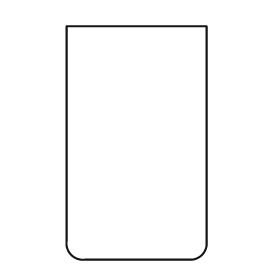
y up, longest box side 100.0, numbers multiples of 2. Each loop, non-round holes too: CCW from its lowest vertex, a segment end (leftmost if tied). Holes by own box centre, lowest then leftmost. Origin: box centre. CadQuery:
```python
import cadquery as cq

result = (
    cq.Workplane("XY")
    .moveTo(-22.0, -50.0)
    .lineTo(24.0, -50.0)
    .threePointArc((28.0, -48.0), (30.0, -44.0))
    .lineTo(30.0, 50.0)
    .lineTo(-30.0, 50.0)
    .lineTo(-30.0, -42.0)
    .threePointArc((-28.0, -48.0), (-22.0, -50.0))
    .close()
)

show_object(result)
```